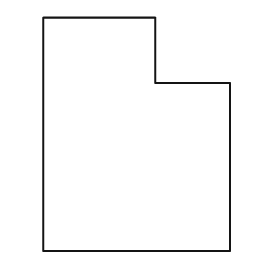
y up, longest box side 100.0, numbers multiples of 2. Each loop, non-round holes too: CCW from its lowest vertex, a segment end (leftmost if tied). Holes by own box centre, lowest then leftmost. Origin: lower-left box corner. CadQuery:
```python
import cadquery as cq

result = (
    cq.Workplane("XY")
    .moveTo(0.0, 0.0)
    .lineTo(80.0, 0.0)
    .lineTo(80.0, 72.0)
    .lineTo(48.0, 72.0)
    .lineTo(48.0, 100.0)
    .lineTo(0.0, 100.0)
    .close()
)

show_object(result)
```